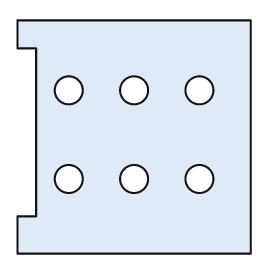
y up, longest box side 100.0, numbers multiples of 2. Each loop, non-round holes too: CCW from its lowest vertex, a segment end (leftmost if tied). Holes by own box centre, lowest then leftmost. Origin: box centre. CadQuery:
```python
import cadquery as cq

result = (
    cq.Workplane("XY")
    .moveTo(-50.0, -50.0)
    .lineTo(50.0, -50.0)
    .lineTo(50.0, 50.0)
    .lineTo(-50.0, 50.0)
    .lineTo(-50.0, 38.0)
    .lineTo(-42.0, 38.0)
    .lineTo(-42.0, -34.0)
    .lineTo(-50.0, -34.0)
    .close()
    .moveTo(-28.0, -18.0)
    .circle(6.0)
    .moveTo(0.0, -18.0)
    .circle(6.0)
    .moveTo(28.0, -18.0)
    .circle(6.0)
    .moveTo(-28.0, 20.0)
    .circle(6.0)
    .moveTo(0.0, 20.0)
    .circle(6.0)
    .moveTo(28.0, 20.0)
    .circle(6.0)
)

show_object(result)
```